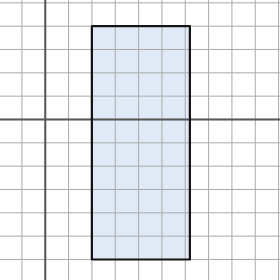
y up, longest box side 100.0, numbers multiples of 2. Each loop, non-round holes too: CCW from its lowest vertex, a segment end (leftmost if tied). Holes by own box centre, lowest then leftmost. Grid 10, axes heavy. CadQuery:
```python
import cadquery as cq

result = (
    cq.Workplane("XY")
    .moveTo(20.0, -60.0)
    .lineTo(62.0, -60.0)
    .lineTo(62.0, 40.0)
    .lineTo(20.0, 40.0)
    .close()
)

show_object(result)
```